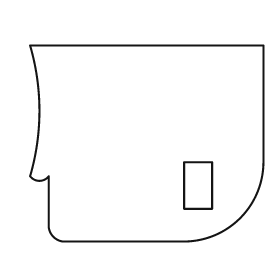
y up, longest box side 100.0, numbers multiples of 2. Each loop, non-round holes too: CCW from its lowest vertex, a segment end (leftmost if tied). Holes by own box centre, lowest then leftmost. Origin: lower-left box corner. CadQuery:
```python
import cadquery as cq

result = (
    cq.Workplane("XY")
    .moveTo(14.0, 0.0)
    .lineTo(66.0, 0.0)
    .threePointArc((90.0, 10.0), (100.0, 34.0))
    .lineTo(100.0, 84.0)
    .lineTo(0.0, 84.0)
    .threePointArc((4.0, 56.0), (0.0, 28.0))
    .threePointArc((4.0, 26.0), (8.0, 28.0))
    .lineTo(8.0, 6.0)
    .threePointArc((10.0, 2.0), (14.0, 0.0))
    .close()
    .moveTo(66.0, 14.0)
    .lineTo(78.0, 14.0)
    .lineTo(78.0, 34.0)
    .lineTo(66.0, 34.0)
    .close()
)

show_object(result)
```